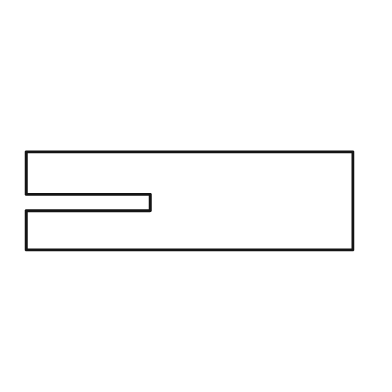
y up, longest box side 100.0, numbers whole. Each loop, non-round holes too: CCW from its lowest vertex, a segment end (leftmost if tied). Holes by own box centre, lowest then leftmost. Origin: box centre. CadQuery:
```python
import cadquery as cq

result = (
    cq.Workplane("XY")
    .moveTo(-50.0, -15.0)
    .lineTo(50.0, -15.0)
    .lineTo(50.0, 15.0)
    .lineTo(-50.0, 15.0)
    .lineTo(-50.0, 2.0)
    .lineTo(-12.0, 2.0)
    .lineTo(-12.0, -3.0)
    .lineTo(-50.0, -3.0)
    .close()
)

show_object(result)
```